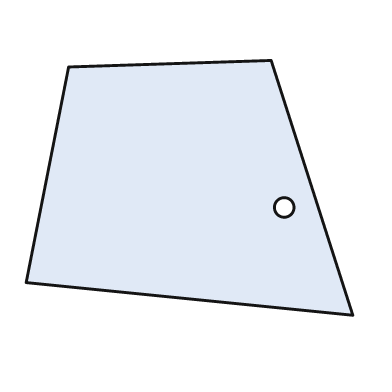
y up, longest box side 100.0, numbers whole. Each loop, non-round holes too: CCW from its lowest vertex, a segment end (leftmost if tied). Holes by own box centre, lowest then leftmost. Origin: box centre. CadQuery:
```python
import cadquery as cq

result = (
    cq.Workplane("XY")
    .moveTo(50.0, -39.0)
    .lineTo(25.0, 39.0)
    .lineTo(-37.0, 37.0)
    .lineTo(-50.0, -29.0)
    .close()
    .moveTo(29.0, -6.0)
    .circle(3.0)
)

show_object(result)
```